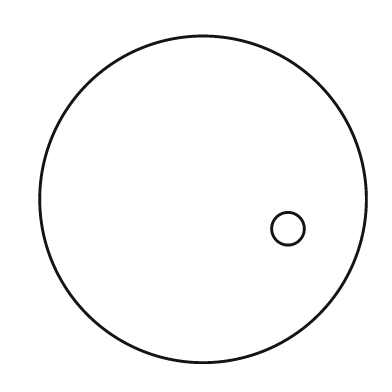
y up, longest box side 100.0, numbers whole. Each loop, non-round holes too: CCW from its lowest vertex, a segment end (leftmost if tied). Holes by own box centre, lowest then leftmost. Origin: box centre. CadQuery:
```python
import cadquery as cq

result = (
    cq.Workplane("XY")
    .moveTo(0.0, 0.0)
    .circle(50.0)
    .moveTo(26.0, -9.0)
    .circle(5.0)
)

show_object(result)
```